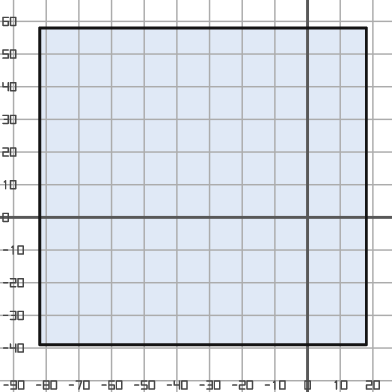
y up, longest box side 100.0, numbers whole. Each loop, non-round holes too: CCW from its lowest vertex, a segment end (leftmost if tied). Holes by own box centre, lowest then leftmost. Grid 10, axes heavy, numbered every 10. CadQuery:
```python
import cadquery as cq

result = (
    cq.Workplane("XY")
    .moveTo(-82.0, -39.0)
    .lineTo(18.0, -39.0)
    .lineTo(18.0, 58.0)
    .lineTo(-82.0, 58.0)
    .close()
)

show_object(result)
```